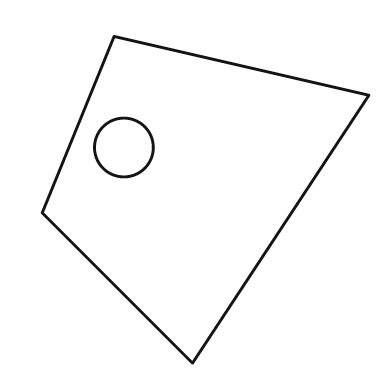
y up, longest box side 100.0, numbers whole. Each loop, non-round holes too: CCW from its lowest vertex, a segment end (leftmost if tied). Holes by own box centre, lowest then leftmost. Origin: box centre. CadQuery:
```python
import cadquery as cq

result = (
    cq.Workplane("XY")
    .moveTo(-4.0, -50.0)
    .lineTo(50.0, 32.0)
    .lineTo(-28.0, 50.0)
    .lineTo(-50.0, -4.0)
    .close()
    .moveTo(-25.0, 16.0)
    .circle(9.0)
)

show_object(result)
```